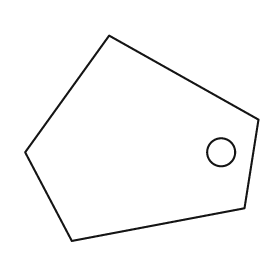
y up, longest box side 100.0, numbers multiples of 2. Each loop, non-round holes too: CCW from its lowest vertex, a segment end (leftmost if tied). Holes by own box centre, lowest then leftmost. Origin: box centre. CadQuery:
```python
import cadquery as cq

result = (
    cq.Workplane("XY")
    .moveTo(-30.0, -44.0)
    .lineTo(44.0, -30.0)
    .lineTo(50.0, 8.0)
    .lineTo(-14.0, 44.0)
    .lineTo(-50.0, -6.0)
    .close()
    .moveTo(34.0, -6.0)
    .circle(6.0)
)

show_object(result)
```